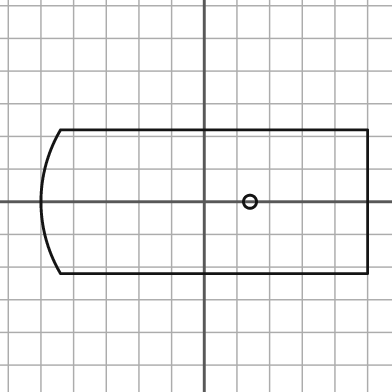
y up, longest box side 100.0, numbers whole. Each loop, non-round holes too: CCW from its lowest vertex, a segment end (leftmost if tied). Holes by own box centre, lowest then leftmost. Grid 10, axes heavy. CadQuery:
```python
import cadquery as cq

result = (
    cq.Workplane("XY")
    .moveTo(-44.0, -22.0)
    .lineTo(50.0, -22.0)
    .lineTo(50.0, 22.0)
    .lineTo(-44.0, 22.0)
    .threePointArc((-50.0, 0.0), (-44.0, -22.0))
    .close()
    .moveTo(14.0, 0.0)
    .circle(2.0)
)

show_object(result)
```